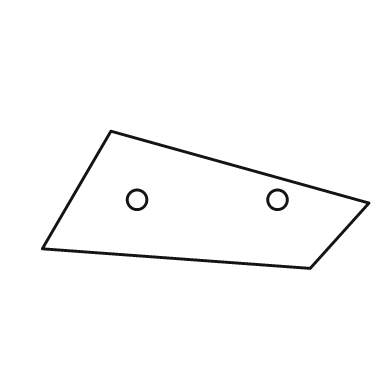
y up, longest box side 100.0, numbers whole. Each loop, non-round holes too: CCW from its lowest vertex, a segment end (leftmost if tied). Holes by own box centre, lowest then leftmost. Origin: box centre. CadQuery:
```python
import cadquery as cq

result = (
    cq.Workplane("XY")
    .moveTo(32.0, -21.0)
    .lineTo(50.0, -1.0)
    .lineTo(-29.0, 21.0)
    .lineTo(-50.0, -15.0)
    .close()
    .moveTo(-21.0, 0.0)
    .circle(3.0)
    .moveTo(22.0, 0.0)
    .circle(3.0)
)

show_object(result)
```